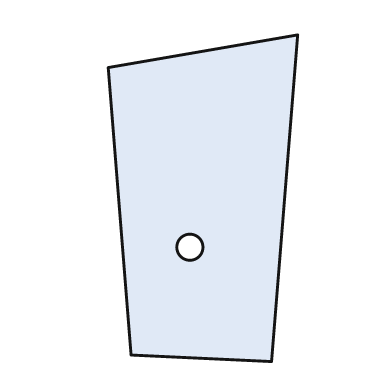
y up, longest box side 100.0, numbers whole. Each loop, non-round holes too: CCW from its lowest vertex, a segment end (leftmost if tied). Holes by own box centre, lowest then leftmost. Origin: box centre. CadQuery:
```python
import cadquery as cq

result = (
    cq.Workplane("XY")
    .moveTo(21.0, -50.0)
    .lineTo(29.0, 50.0)
    .lineTo(-29.0, 40.0)
    .lineTo(-22.0, -48.0)
    .close()
    .moveTo(-4.0, -15.0)
    .circle(4.0)
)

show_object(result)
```